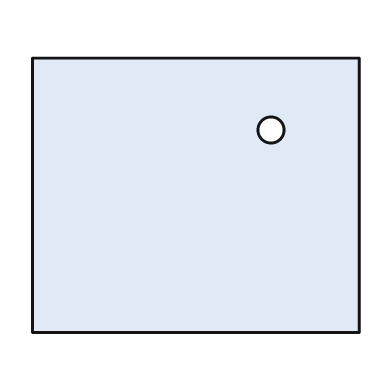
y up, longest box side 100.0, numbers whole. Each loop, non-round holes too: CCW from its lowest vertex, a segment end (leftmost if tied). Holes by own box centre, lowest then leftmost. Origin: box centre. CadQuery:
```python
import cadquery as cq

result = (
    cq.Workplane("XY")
    .moveTo(-50.0, -42.0)
    .lineTo(50.0, -42.0)
    .lineTo(50.0, 42.0)
    .lineTo(-50.0, 42.0)
    .close()
    .moveTo(23.0, 20.0)
    .circle(4.0)
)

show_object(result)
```